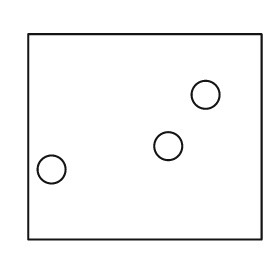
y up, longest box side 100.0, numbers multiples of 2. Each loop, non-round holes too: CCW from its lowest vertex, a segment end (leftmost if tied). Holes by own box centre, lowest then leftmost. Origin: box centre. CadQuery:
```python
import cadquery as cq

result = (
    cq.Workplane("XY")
    .moveTo(-50.0, -44.0)
    .lineTo(50.0, -44.0)
    .lineTo(50.0, 44.0)
    .lineTo(-50.0, 44.0)
    .close()
    .moveTo(-40.0, -14.0)
    .circle(6.0)
    .moveTo(10.0, -4.0)
    .circle(6.0)
    .moveTo(26.0, 18.0)
    .circle(6.0)
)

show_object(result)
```